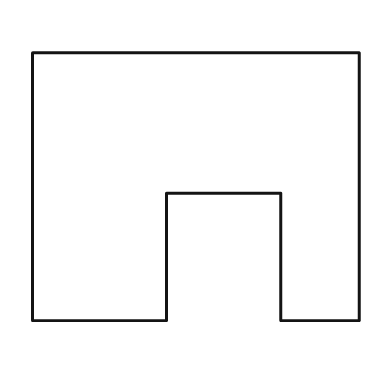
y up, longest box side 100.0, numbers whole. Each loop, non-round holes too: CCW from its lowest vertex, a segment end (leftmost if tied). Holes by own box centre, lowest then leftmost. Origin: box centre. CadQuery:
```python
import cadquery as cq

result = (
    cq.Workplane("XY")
    .moveTo(-50.0, -41.0)
    .lineTo(-9.0, -41.0)
    .lineTo(-9.0, -2.0)
    .lineTo(26.0, -2.0)
    .lineTo(26.0, -41.0)
    .lineTo(50.0, -41.0)
    .lineTo(50.0, 41.0)
    .lineTo(-50.0, 41.0)
    .close()
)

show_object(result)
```